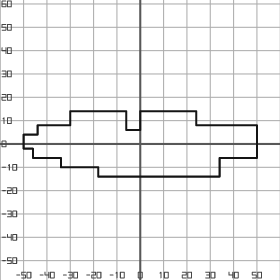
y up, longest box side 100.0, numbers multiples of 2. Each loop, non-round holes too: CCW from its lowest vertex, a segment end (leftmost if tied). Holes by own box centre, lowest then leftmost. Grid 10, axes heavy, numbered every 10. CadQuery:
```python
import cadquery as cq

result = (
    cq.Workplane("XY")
    .moveTo(-18.0, -14.0)
    .lineTo(34.0, -14.0)
    .lineTo(34.0, -6.0)
    .lineTo(50.0, -6.0)
    .lineTo(50.0, 8.0)
    .lineTo(24.0, 8.0)
    .lineTo(24.0, 14.0)
    .lineTo(0.0, 14.0)
    .lineTo(0.0, 6.0)
    .lineTo(-6.0, 6.0)
    .lineTo(-6.0, 14.0)
    .lineTo(-30.0, 14.0)
    .lineTo(-30.0, 8.0)
    .lineTo(-44.0, 8.0)
    .lineTo(-44.0, 4.0)
    .lineTo(-50.0, 4.0)
    .lineTo(-50.0, -2.0)
    .lineTo(-46.0, -2.0)
    .lineTo(-46.0, -6.0)
    .lineTo(-34.0, -6.0)
    .lineTo(-34.0, -10.0)
    .lineTo(-18.0, -10.0)
    .close()
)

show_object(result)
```